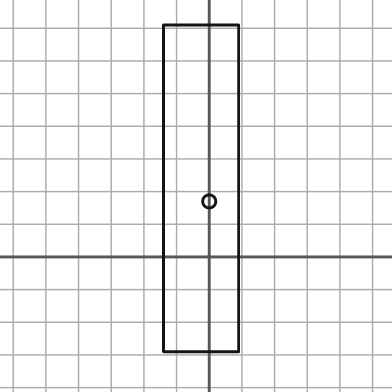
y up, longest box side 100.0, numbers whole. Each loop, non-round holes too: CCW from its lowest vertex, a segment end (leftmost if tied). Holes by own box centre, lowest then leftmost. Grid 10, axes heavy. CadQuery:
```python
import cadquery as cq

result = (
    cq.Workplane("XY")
    .moveTo(-14.0, -29.0)
    .lineTo(9.0, -29.0)
    .lineTo(9.0, 71.0)
    .lineTo(-14.0, 71.0)
    .close()
    .moveTo(0.0, 17.0)
    .circle(2.0)
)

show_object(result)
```